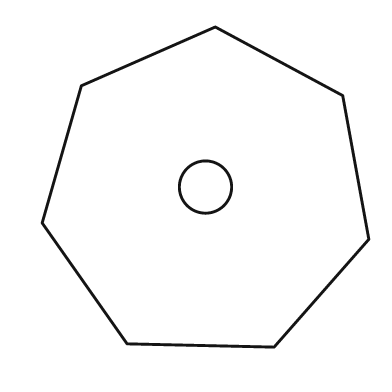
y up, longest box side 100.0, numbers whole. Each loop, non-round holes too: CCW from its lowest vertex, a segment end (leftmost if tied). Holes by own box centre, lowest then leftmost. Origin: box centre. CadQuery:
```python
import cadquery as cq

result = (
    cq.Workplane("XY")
    .moveTo(21.0, -49.0)
    .lineTo(50.0, -16.0)
    .lineTo(42.0, 28.0)
    .lineTo(3.0, 49.0)
    .lineTo(-38.0, 31.0)
    .lineTo(-50.0, -11.0)
    .lineTo(-24.0, -48.0)
    .close()
    .moveTo(0.0, 0.0)
    .circle(8.0)
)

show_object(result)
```